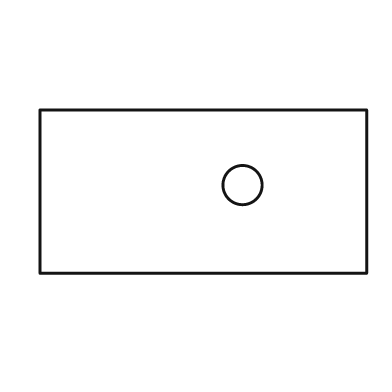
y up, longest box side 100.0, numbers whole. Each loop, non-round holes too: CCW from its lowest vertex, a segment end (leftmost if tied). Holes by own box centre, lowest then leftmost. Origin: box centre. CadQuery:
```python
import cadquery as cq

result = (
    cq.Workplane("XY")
    .moveTo(-50.0, -25.0)
    .lineTo(50.0, -25.0)
    .lineTo(50.0, 25.0)
    .lineTo(-50.0, 25.0)
    .close()
    .moveTo(12.0, 2.0)
    .circle(6.0)
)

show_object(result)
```